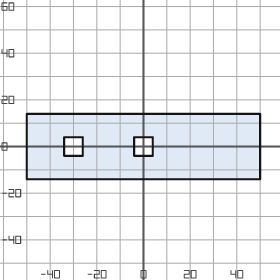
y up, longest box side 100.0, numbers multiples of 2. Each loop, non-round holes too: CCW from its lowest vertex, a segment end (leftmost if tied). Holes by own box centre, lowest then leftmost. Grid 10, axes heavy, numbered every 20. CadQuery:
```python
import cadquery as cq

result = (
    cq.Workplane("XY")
    .moveTo(-50.0, -14.0)
    .lineTo(50.0, -14.0)
    .lineTo(50.0, 14.0)
    .lineTo(-50.0, 14.0)
    .close()
    .moveTo(-34.0, -4.0)
    .lineTo(-26.0, -4.0)
    .lineTo(-26.0, 4.0)
    .lineTo(-34.0, 4.0)
    .close()
    .moveTo(-4.0, -4.0)
    .lineTo(4.0, -4.0)
    .lineTo(4.0, 4.0)
    .lineTo(-4.0, 4.0)
    .close()
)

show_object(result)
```